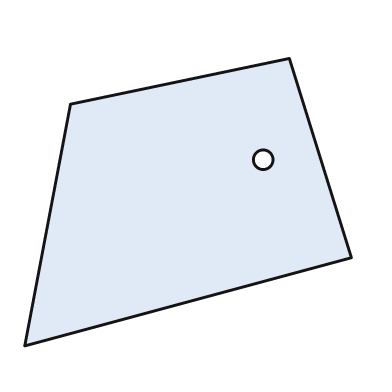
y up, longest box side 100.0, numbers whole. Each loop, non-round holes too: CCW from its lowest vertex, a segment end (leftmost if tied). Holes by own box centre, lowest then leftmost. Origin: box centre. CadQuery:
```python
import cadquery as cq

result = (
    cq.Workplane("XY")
    .moveTo(-50.0, -44.0)
    .lineTo(50.0, -17.0)
    .lineTo(31.0, 44.0)
    .lineTo(-36.0, 30.0)
    .close()
    .moveTo(23.0, 13.0)
    .circle(3.0)
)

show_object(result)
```